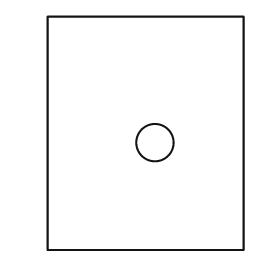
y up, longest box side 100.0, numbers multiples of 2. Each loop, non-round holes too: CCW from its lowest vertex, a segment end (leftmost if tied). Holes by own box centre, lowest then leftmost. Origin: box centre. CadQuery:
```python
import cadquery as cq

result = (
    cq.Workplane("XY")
    .moveTo(-42.0, -50.0)
    .lineTo(42.0, -50.0)
    .lineTo(42.0, 50.0)
    .lineTo(-42.0, 50.0)
    .close()
    .moveTo(4.0, -4.0)
    .circle(8.0)
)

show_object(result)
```